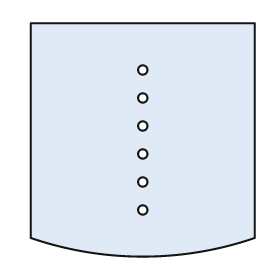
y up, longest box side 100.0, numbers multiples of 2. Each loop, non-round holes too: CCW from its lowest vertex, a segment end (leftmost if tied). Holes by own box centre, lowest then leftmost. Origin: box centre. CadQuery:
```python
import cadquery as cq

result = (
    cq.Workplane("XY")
    .moveTo(-48.0, -42.0)
    .threePointArc((0.0, -50.0), (48.0, -42.0))
    .lineTo(48.0, 50.0)
    .lineTo(-48.0, 50.0)
    .close()
    .moveTo(0.0, -30.0)
    .circle(2.0)
    .moveTo(0.0, -18.0)
    .circle(2.0)
    .moveTo(0.0, -6.0)
    .circle(2.0)
    .moveTo(0.0, 6.0)
    .circle(2.0)
    .moveTo(0.0, 18.0)
    .circle(2.0)
    .moveTo(0.0, 30.0)
    .circle(2.0)
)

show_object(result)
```